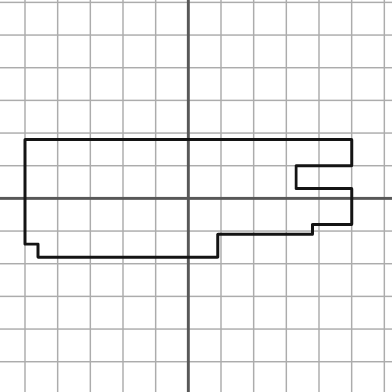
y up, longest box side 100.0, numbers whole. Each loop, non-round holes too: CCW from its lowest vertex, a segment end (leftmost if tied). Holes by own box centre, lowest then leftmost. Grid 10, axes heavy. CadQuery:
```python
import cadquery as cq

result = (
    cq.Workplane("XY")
    .moveTo(-46.0, -18.0)
    .lineTo(9.0, -18.0)
    .lineTo(9.0, -11.0)
    .lineTo(38.0, -11.0)
    .lineTo(38.0, -8.0)
    .lineTo(50.0, -8.0)
    .lineTo(50.0, 3.0)
    .lineTo(33.0, 3.0)
    .lineTo(33.0, 10.0)
    .lineTo(50.0, 10.0)
    .lineTo(50.0, 18.0)
    .lineTo(-50.0, 18.0)
    .lineTo(-50.0, -14.0)
    .lineTo(-46.0, -14.0)
    .close()
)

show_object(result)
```